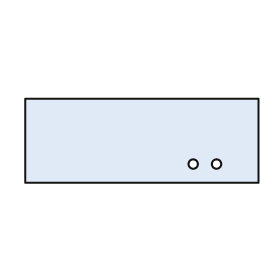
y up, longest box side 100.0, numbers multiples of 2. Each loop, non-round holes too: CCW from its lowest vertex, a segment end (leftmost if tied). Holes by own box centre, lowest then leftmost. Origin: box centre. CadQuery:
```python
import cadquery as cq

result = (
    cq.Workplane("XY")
    .moveTo(-50.0, -18.0)
    .lineTo(50.0, -18.0)
    .lineTo(50.0, 18.0)
    .lineTo(-50.0, 18.0)
    .close()
    .moveTo(22.0, -10.0)
    .circle(2.0)
    .moveTo(32.0, -10.0)
    .circle(2.0)
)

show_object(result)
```